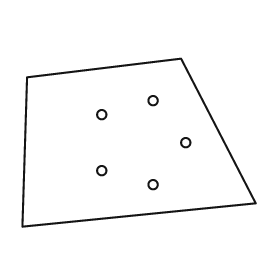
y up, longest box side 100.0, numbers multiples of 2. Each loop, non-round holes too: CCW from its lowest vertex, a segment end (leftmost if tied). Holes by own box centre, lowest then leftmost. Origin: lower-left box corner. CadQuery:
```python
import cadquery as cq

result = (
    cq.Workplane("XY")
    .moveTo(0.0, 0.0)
    .lineTo(100.0, 10.0)
    .lineTo(68.0, 72.0)
    .lineTo(2.0, 64.0)
    .close()
    .moveTo(56.0, 18.0)
    .circle(2.0)
    .moveTo(34.0, 24.0)
    .circle(2.0)
    .moveTo(70.0, 36.0)
    .circle(2.0)
    .moveTo(34.0, 48.0)
    .circle(2.0)
    .moveTo(56.0, 54.0)
    .circle(2.0)
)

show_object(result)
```